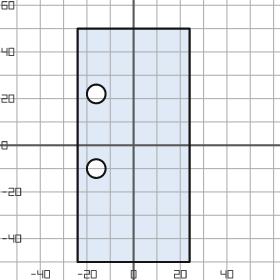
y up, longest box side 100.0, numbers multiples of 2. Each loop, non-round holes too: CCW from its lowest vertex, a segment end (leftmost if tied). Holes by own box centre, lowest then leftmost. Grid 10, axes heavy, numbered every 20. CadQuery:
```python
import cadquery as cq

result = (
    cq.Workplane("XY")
    .moveTo(-24.0, -50.0)
    .lineTo(24.0, -50.0)
    .lineTo(24.0, 50.0)
    .lineTo(-24.0, 50.0)
    .close()
    .moveTo(-16.0, -10.0)
    .circle(4.0)
    .moveTo(-16.0, 22.0)
    .circle(4.0)
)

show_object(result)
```